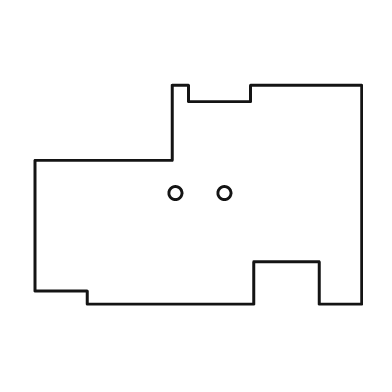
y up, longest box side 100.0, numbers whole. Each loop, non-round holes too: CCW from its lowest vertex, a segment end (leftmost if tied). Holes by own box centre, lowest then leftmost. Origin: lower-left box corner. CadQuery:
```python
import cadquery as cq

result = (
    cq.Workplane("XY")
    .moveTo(16.0, 0.0)
    .lineTo(67.0, 0.0)
    .lineTo(67.0, 13.0)
    .lineTo(87.0, 13.0)
    .lineTo(87.0, 0.0)
    .lineTo(100.0, 0.0)
    .lineTo(100.0, 67.0)
    .lineTo(66.0, 67.0)
    .lineTo(66.0, 62.0)
    .lineTo(47.0, 62.0)
    .lineTo(47.0, 67.0)
    .lineTo(42.0, 67.0)
    .lineTo(42.0, 44.0)
    .lineTo(0.0, 44.0)
    .lineTo(0.0, 4.0)
    .lineTo(16.0, 4.0)
    .close()
    .moveTo(43.0, 34.0)
    .circle(2.0)
    .moveTo(58.0, 34.0)
    .circle(2.0)
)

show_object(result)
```